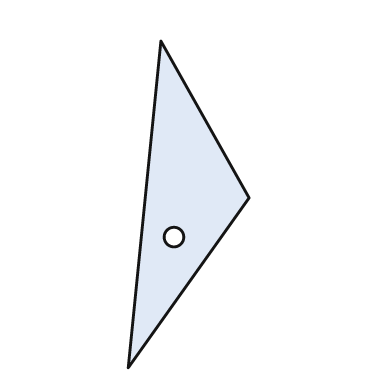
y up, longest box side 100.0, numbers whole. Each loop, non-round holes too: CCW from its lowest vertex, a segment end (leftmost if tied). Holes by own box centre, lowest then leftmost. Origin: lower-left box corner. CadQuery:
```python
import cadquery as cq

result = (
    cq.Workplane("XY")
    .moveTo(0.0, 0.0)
    .lineTo(37.0, 52.0)
    .lineTo(10.0, 100.0)
    .close()
    .moveTo(14.0, 40.0)
    .circle(3.0)
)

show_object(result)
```